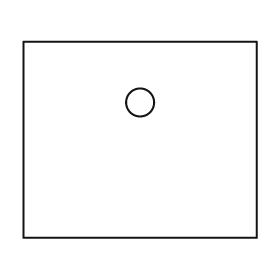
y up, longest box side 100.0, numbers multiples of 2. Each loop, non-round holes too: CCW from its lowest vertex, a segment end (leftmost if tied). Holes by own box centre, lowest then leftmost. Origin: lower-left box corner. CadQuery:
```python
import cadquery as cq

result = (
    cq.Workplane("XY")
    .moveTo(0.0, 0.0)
    .lineTo(100.0, 0.0)
    .lineTo(100.0, 84.0)
    .lineTo(0.0, 84.0)
    .close()
    .moveTo(50.0, 58.0)
    .circle(6.0)
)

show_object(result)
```